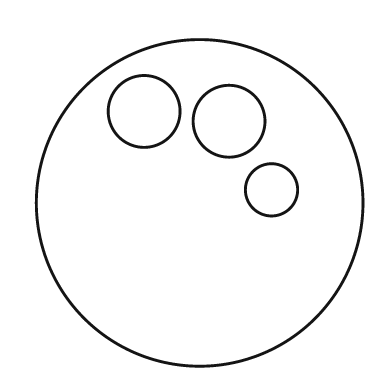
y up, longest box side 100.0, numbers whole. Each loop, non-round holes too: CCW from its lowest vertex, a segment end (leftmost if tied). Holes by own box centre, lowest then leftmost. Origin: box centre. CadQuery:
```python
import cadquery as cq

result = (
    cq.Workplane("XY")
    .moveTo(0.0, 0.0)
    .circle(50.0)
    .moveTo(22.0, 4.0)
    .circle(8.0)
    .moveTo(9.0, 25.0)
    .circle(11.0)
    .moveTo(-17.0, 28.0)
    .circle(11.0)
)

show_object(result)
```